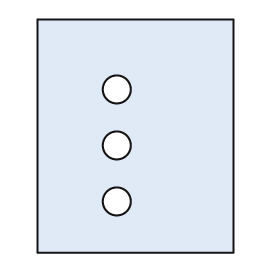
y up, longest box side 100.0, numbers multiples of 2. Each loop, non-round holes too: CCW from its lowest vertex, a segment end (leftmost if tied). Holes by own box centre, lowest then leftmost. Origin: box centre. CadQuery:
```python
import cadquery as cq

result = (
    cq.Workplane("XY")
    .moveTo(-42.0, -50.0)
    .lineTo(42.0, -50.0)
    .lineTo(42.0, 50.0)
    .lineTo(-42.0, 50.0)
    .close()
    .moveTo(-8.0, -28.0)
    .circle(6.0)
    .moveTo(-8.0, -4.0)
    .circle(6.0)
    .moveTo(-8.0, 20.0)
    .circle(6.0)
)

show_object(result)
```